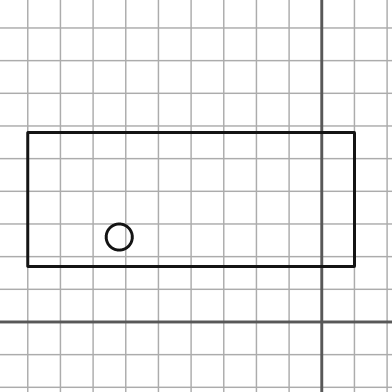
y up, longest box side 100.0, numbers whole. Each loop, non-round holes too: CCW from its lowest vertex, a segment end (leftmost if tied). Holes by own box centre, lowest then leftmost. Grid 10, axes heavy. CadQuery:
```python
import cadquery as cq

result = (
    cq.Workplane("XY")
    .moveTo(-90.0, 17.0)
    .lineTo(10.0, 17.0)
    .lineTo(10.0, 58.0)
    .lineTo(-90.0, 58.0)
    .close()
    .moveTo(-62.0, 26.0)
    .circle(4.0)
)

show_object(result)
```